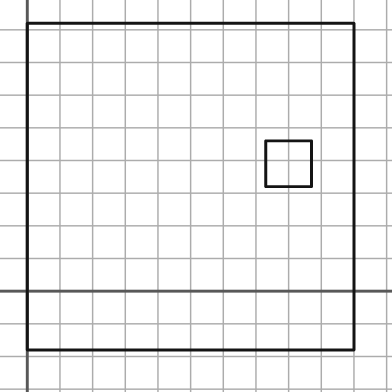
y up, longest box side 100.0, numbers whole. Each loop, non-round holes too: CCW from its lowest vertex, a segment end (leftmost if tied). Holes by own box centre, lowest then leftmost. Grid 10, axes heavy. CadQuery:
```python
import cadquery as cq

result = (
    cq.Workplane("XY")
    .moveTo(0.0, -18.0)
    .lineTo(100.0, -18.0)
    .lineTo(100.0, 82.0)
    .lineTo(0.0, 82.0)
    .close()
    .moveTo(73.0, 32.0)
    .lineTo(87.0, 32.0)
    .lineTo(87.0, 46.0)
    .lineTo(73.0, 46.0)
    .close()
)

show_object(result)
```